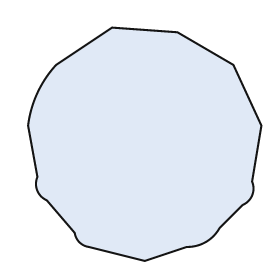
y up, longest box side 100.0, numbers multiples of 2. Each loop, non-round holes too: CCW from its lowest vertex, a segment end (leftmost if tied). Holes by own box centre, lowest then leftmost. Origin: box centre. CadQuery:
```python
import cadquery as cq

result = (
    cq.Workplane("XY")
    .moveTo(0.0, -50.0)
    .lineTo(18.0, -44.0)
    .threePointArc((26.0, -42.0), (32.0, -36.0))
    .lineTo(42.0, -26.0)
    .threePointArc((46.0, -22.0), (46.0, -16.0))
    .lineTo(50.0, 8.0)
    .lineTo(38.0, 34.0)
    .lineTo(14.0, 48.0)
    .lineTo(-14.0, 50.0)
    .lineTo(-38.0, 34.0)
    .threePointArc((-46.0, 22.0), (-50.0, 8.0))
    .lineTo(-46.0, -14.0)
    .threePointArc((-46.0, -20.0), (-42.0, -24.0))
    .lineTo(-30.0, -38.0)
    .threePointArc((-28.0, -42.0), (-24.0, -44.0))
    .close()
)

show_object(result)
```